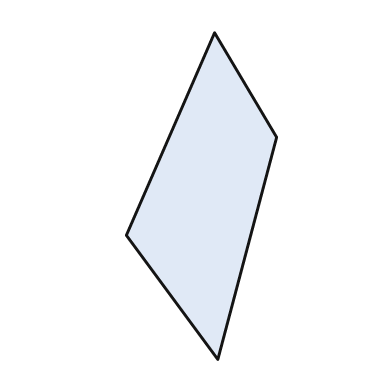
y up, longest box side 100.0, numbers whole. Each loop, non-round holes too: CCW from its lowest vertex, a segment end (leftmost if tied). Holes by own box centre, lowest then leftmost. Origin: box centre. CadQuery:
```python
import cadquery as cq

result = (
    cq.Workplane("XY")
    .moveTo(5.0, -50.0)
    .lineTo(23.0, 18.0)
    .lineTo(4.0, 50.0)
    .lineTo(-23.0, -12.0)
    .close()
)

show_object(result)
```